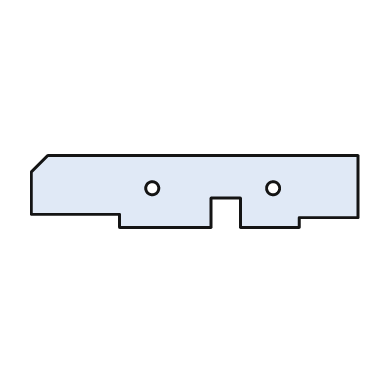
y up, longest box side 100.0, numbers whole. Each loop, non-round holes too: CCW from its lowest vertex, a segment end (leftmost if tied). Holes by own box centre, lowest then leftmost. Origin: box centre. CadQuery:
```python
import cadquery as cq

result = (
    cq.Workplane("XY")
    .moveTo(-23.0, -11.0)
    .lineTo(5.0, -11.0)
    .lineTo(5.0, -2.0)
    .lineTo(14.0, -2.0)
    .lineTo(14.0, -11.0)
    .lineTo(32.0, -11.0)
    .lineTo(32.0, -8.0)
    .lineTo(50.0, -8.0)
    .lineTo(50.0, 11.0)
    .lineTo(-45.0, 11.0)
    .lineTo(-50.0, 6.0)
    .lineTo(-50.0, -7.0)
    .lineTo(-23.0, -7.0)
    .close()
    .moveTo(-13.0, 1.0)
    .circle(2.0)
    .moveTo(24.0, 1.0)
    .circle(2.0)
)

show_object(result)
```